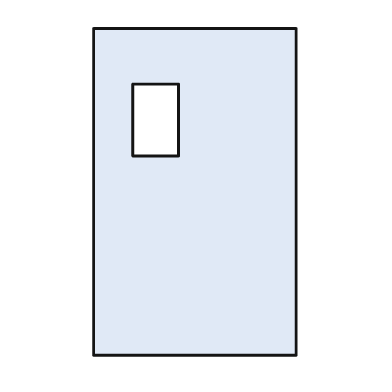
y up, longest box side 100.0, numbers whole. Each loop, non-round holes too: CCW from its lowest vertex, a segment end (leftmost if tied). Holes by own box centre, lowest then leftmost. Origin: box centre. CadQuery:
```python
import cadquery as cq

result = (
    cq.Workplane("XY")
    .moveTo(-31.0, -50.0)
    .lineTo(31.0, -50.0)
    .lineTo(31.0, 50.0)
    .lineTo(-31.0, 50.0)
    .close()
    .moveTo(-19.0, 11.0)
    .lineTo(-5.0, 11.0)
    .lineTo(-5.0, 33.0)
    .lineTo(-19.0, 33.0)
    .close()
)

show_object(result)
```